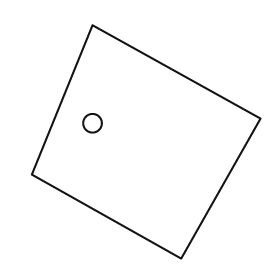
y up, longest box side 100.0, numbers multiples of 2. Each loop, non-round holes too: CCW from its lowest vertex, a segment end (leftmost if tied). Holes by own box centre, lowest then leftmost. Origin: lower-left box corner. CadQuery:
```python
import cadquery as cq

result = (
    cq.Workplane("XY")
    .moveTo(64.0, 0.0)
    .lineTo(98.0, 60.0)
    .lineTo(26.0, 100.0)
    .lineTo(0.0, 36.0)
    .close()
    .moveTo(26.0, 58.0)
    .circle(4.0)
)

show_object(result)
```